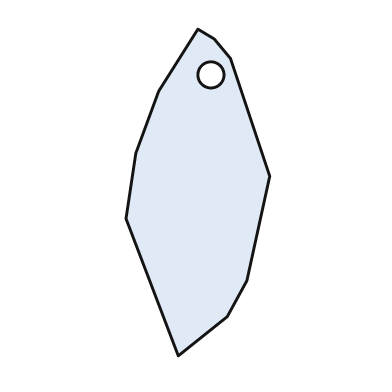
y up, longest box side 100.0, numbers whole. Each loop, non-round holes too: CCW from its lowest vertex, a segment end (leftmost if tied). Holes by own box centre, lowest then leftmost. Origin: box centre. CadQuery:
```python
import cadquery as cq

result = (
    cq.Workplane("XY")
    .moveTo(-6.0, -50.0)
    .lineTo(9.0, -38.0)
    .lineTo(15.0, -27.0)
    .lineTo(22.0, 5.0)
    .lineTo(10.0, 41.0)
    .lineTo(5.0, 47.0)
    .lineTo(0.0, 50.0)
    .lineTo(-12.0, 31.0)
    .lineTo(-19.0, 12.0)
    .lineTo(-22.0, -8.0)
    .close()
    .moveTo(4.0, 36.0)
    .circle(4.0)
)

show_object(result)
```